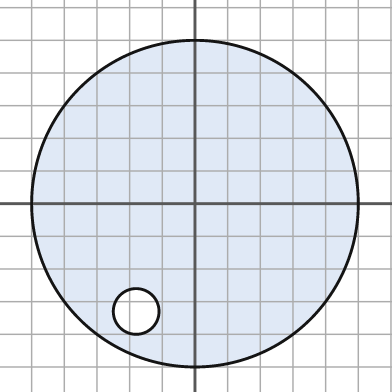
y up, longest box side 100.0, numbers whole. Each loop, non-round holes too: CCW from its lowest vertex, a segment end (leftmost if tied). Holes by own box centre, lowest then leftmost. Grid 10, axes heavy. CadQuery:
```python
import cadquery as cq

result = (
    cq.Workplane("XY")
    .moveTo(0.0, 0.0)
    .circle(50.0)
    .moveTo(-18.0, -33.0)
    .circle(7.0)
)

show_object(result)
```